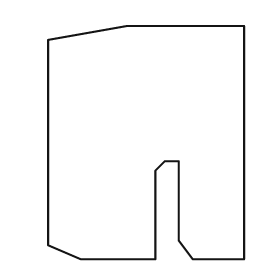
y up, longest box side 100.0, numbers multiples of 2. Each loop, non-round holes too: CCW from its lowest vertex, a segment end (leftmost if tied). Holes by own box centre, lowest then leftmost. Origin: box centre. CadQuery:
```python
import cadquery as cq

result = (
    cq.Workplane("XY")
    .moveTo(-28.0, -50.0)
    .lineTo(4.0, -50.0)
    .lineTo(4.0, -12.0)
    .lineTo(8.0, -8.0)
    .lineTo(14.0, -8.0)
    .lineTo(14.0, -42.0)
    .lineTo(20.0, -50.0)
    .lineTo(42.0, -50.0)
    .lineTo(42.0, 50.0)
    .lineTo(-8.0, 50.0)
    .lineTo(-42.0, 44.0)
    .lineTo(-42.0, -44.0)
    .close()
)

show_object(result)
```